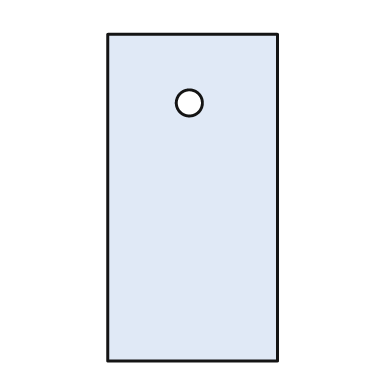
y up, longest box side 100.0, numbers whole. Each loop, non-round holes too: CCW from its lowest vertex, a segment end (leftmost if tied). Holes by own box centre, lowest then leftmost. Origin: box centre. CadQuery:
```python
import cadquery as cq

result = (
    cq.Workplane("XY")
    .moveTo(-26.0, -50.0)
    .lineTo(26.0, -50.0)
    .lineTo(26.0, 50.0)
    .lineTo(-26.0, 50.0)
    .close()
    .moveTo(-1.0, 29.0)
    .circle(4.0)
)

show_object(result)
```